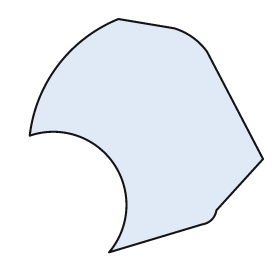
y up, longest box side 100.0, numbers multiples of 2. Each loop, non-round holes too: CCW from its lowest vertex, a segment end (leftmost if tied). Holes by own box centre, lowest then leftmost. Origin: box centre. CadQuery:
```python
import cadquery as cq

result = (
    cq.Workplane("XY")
    .moveTo(-16.0, -50.0)
    .lineTo(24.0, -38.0)
    .threePointArc((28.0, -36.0), (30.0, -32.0))
    .lineTo(50.0, -10.0)
    .lineTo(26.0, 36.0)
    .threePointArc((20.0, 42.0), (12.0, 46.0))
    .lineTo(-12.0, 50.0)
    .threePointArc((-38.0, 30.0), (-50.0, 0.0))
    .threePointArc((-14.0, -12.0), (-16.0, -50.0))
    .close()
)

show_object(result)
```